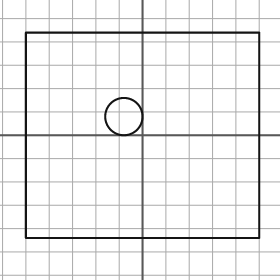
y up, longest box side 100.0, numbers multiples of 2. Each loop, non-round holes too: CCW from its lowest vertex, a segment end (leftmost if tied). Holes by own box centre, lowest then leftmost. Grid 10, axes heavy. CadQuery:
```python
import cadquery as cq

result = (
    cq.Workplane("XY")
    .moveTo(-50.0, -44.0)
    .lineTo(50.0, -44.0)
    .lineTo(50.0, 44.0)
    .lineTo(-50.0, 44.0)
    .close()
    .moveTo(-8.0, 8.0)
    .circle(8.0)
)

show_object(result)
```